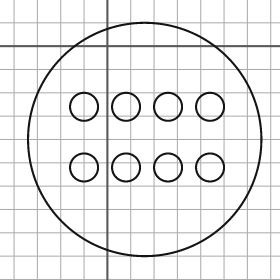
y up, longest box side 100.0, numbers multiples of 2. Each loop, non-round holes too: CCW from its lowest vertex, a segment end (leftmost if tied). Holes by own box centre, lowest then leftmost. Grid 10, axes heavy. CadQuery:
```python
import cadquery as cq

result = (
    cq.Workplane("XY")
    .moveTo(16.0, -40.0)
    .circle(50.0)
    .moveTo(-10.0, -52.0)
    .circle(6.0)
    .moveTo(8.0, -52.0)
    .circle(6.0)
    .moveTo(26.0, -52.0)
    .circle(6.0)
    .moveTo(44.0, -52.0)
    .circle(6.0)
    .moveTo(-10.0, -26.0)
    .circle(6.0)
    .moveTo(8.0, -26.0)
    .circle(6.0)
    .moveTo(26.0, -26.0)
    .circle(6.0)
    .moveTo(44.0, -26.0)
    .circle(6.0)
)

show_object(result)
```